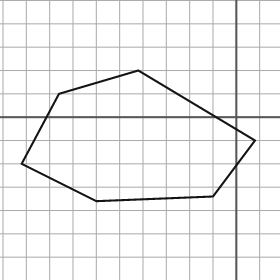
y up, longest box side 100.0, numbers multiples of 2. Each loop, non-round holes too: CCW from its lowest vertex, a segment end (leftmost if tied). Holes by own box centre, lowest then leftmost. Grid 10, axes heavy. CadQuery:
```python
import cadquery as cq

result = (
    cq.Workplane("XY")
    .moveTo(-60.0, -36.0)
    .lineTo(-10.0, -34.0)
    .lineTo(8.0, -10.0)
    .lineTo(-42.0, 20.0)
    .lineTo(-76.0, 10.0)
    .lineTo(-92.0, -20.0)
    .close()
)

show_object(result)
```